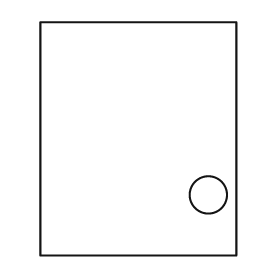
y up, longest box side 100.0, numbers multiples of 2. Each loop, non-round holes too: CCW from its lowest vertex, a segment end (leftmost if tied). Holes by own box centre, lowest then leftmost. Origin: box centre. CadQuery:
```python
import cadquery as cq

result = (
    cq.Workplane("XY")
    .moveTo(-42.0, -50.0)
    .lineTo(42.0, -50.0)
    .lineTo(42.0, 50.0)
    .lineTo(-42.0, 50.0)
    .close()
    .moveTo(30.0, -24.0)
    .circle(8.0)
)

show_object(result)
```